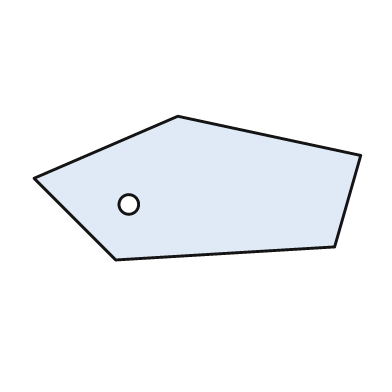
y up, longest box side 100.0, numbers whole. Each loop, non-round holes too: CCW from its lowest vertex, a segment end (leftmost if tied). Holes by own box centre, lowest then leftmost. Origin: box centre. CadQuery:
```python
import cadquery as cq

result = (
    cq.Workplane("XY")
    .moveTo(-25.0, -22.0)
    .lineTo(42.0, -18.0)
    .lineTo(50.0, 10.0)
    .lineTo(-6.0, 22.0)
    .lineTo(-50.0, 3.0)
    .close()
    .moveTo(-21.0, -5.0)
    .circle(3.0)
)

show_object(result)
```